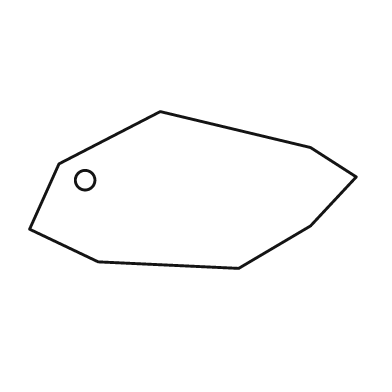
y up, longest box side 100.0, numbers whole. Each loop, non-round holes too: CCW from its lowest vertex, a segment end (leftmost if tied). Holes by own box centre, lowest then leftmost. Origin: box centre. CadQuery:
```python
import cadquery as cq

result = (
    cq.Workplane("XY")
    .moveTo(14.0, -24.0)
    .lineTo(36.0, -11.0)
    .lineTo(50.0, 4.0)
    .lineTo(36.0, 13.0)
    .lineTo(-10.0, 24.0)
    .lineTo(-41.0, 8.0)
    .lineTo(-50.0, -12.0)
    .lineTo(-29.0, -22.0)
    .close()
    .moveTo(-33.0, 3.0)
    .circle(3.0)
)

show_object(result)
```